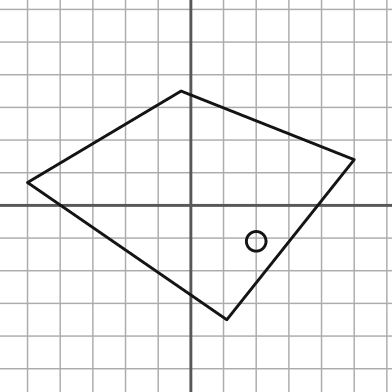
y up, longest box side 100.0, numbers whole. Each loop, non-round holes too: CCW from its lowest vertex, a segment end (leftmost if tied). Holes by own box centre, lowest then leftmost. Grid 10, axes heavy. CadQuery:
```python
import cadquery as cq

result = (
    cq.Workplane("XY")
    .moveTo(11.0, -35.0)
    .lineTo(50.0, 14.0)
    .lineTo(-3.0, 35.0)
    .lineTo(-50.0, 7.0)
    .close()
    .moveTo(20.0, -11.0)
    .circle(3.0)
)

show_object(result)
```